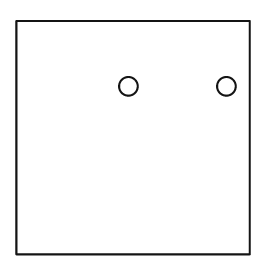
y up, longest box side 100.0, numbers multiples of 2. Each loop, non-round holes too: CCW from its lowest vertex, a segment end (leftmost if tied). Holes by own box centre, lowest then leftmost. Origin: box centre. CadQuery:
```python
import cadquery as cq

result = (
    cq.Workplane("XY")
    .moveTo(-50.0, -50.0)
    .lineTo(50.0, -50.0)
    .lineTo(50.0, 50.0)
    .lineTo(-50.0, 50.0)
    .close()
    .moveTo(-2.0, 22.0)
    .circle(4.0)
    .moveTo(40.0, 22.0)
    .circle(4.0)
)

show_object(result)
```